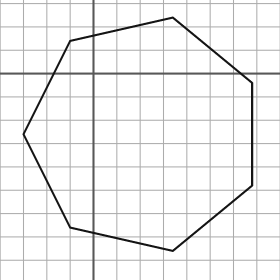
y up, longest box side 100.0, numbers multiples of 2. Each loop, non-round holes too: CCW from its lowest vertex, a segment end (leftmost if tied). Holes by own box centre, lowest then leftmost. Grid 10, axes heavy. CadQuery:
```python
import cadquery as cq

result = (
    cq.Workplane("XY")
    .moveTo(34.0, -76.0)
    .lineTo(68.0, -48.0)
    .lineTo(68.0, -4.0)
    .lineTo(34.0, 24.0)
    .lineTo(-10.0, 14.0)
    .lineTo(-30.0, -26.0)
    .lineTo(-10.0, -66.0)
    .close()
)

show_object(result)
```